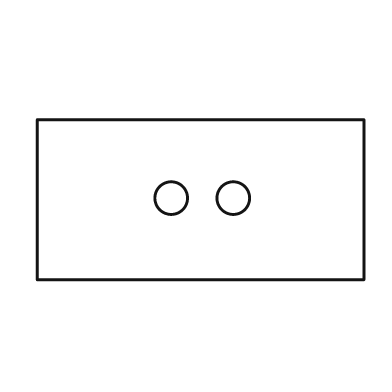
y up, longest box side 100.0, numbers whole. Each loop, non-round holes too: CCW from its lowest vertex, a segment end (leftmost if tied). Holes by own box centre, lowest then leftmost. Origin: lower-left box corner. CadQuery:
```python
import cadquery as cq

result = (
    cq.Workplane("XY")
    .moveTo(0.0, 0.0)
    .lineTo(100.0, 0.0)
    .lineTo(100.0, 49.0)
    .lineTo(0.0, 49.0)
    .close()
    .moveTo(41.0, 25.0)
    .circle(5.0)
    .moveTo(60.0, 25.0)
    .circle(5.0)
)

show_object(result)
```